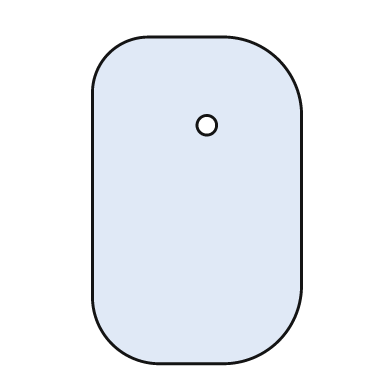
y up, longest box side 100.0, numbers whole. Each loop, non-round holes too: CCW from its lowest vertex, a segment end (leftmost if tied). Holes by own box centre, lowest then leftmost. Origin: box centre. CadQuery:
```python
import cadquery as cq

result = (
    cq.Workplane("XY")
    .moveTo(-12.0, -50.0)
    .lineTo(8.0, -50.0)
    .threePointArc((25.0, -43.0), (32.0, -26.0))
    .lineTo(32.0, 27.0)
    .threePointArc((25.0, 43.0), (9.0, 50.0))
    .lineTo(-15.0, 50.0)
    .threePointArc((-27.0, 45.0), (-32.0, 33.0))
    .lineTo(-32.0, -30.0)
    .threePointArc((-26.0, -44.0), (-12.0, -50.0))
    .close()
    .moveTo(3.0, 23.0)
    .circle(3.0)
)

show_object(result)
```